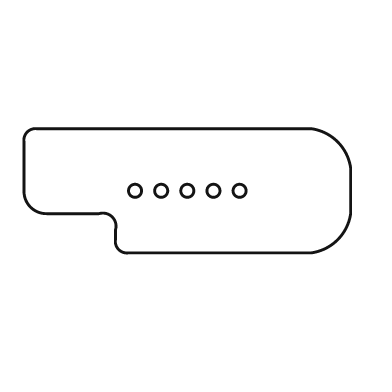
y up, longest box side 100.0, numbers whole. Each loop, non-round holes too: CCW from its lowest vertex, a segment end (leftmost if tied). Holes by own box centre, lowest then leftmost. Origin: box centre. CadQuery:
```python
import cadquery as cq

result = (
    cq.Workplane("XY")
    .moveTo(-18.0, -19.0)
    .lineTo(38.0, -19.0)
    .threePointArc((46.0, -15.0), (50.0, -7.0))
    .lineTo(50.0, 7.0)
    .threePointArc((46.0, 15.0), (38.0, 19.0))
    .lineTo(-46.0, 19.0)
    .threePointArc((-49.0, 18.0), (-50.0, 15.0))
    .lineTo(-50.0, 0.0)
    .threePointArc((-48.0, -5.0), (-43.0, -7.0))
    .lineTo(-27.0, -7.0)
    .threePointArc((-23.0, -8.0), (-22.0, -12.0))
    .lineTo(-22.0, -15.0)
    .threePointArc((-21.0, -18.0), (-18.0, -19.0))
    .close()
    .moveTo(-16.0, 0.0)
    .circle(2.0)
    .moveTo(-8.0, 0.0)
    .circle(2.0)
    .moveTo(0.0, 0.0)
    .circle(2.0)
    .moveTo(8.0, 0.0)
    .circle(2.0)
    .moveTo(16.0, 0.0)
    .circle(2.0)
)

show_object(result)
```